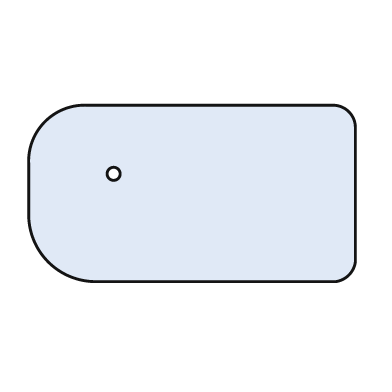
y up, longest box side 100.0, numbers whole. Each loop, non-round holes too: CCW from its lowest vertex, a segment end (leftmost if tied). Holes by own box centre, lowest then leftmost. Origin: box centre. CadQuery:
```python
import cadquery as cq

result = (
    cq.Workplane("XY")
    .moveTo(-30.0, -27.0)
    .lineTo(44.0, -27.0)
    .threePointArc((48.0, -25.0), (50.0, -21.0))
    .lineTo(50.0, 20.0)
    .threePointArc((48.0, 25.0), (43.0, 27.0))
    .lineTo(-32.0, 27.0)
    .threePointArc((-45.0, 22.0), (-50.0, 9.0))
    .lineTo(-50.0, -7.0)
    .threePointArc((-44.0, -21.0), (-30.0, -27.0))
    .close()
    .moveTo(-24.0, 6.0)
    .circle(2.0)
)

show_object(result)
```